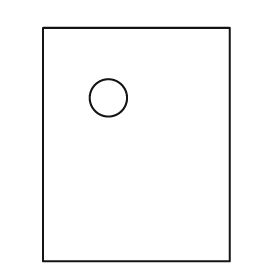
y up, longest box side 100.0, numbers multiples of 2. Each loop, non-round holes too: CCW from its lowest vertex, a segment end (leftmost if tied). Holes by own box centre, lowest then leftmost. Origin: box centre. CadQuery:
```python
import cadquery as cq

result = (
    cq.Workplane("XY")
    .moveTo(-40.0, -50.0)
    .lineTo(40.0, -50.0)
    .lineTo(40.0, 50.0)
    .lineTo(-40.0, 50.0)
    .close()
    .moveTo(-12.0, 20.0)
    .circle(8.0)
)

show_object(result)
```